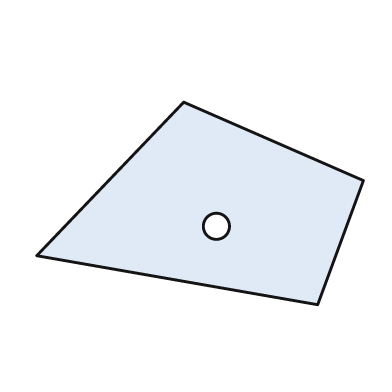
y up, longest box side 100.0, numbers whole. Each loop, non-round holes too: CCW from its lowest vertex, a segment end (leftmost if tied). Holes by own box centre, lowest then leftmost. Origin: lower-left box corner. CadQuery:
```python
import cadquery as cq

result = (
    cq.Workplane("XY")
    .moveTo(86.0, 0.0)
    .lineTo(100.0, 38.0)
    .lineTo(45.0, 62.0)
    .lineTo(0.0, 15.0)
    .close()
    .moveTo(55.0, 24.0)
    .circle(4.0)
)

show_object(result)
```